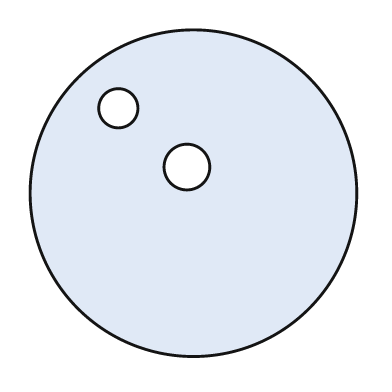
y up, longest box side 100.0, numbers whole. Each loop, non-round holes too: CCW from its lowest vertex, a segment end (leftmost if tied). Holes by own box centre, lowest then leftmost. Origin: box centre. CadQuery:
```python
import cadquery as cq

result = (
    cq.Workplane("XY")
    .moveTo(0.0, 0.0)
    .circle(50.0)
    .moveTo(-2.0, 8.0)
    .circle(7.0)
    .moveTo(-23.0, 26.0)
    .circle(6.0)
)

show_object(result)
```